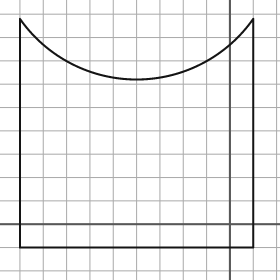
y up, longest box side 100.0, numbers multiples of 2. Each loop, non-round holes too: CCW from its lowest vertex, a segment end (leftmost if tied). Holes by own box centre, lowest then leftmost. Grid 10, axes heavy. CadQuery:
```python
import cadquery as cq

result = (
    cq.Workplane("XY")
    .moveTo(-90.0, -10.0)
    .lineTo(10.0, -10.0)
    .lineTo(10.0, 88.0)
    .threePointArc((-40.0, 62.0), (-90.0, 88.0))
    .close()
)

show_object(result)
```